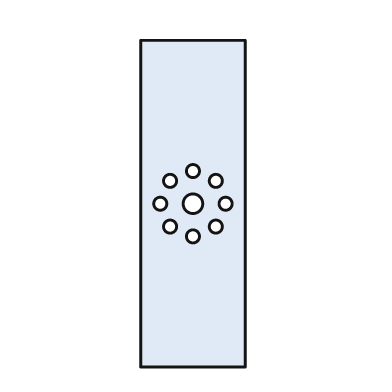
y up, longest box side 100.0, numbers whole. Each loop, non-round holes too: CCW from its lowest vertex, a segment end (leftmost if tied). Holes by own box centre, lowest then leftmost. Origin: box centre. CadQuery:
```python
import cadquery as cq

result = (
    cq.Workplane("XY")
    .moveTo(-16.0, -50.0)
    .lineTo(16.0, -50.0)
    .lineTo(16.0, 50.0)
    .lineTo(-16.0, 50.0)
    .close()
    .moveTo(0.0, -10.0)
    .circle(2.0)
    .moveTo(-7.0, -7.0)
    .circle(2.0)
    .moveTo(7.0, -7.0)
    .circle(2.0)
    .moveTo(-10.0, 0.0)
    .circle(2.0)
    .moveTo(0.0, 0.0)
    .circle(3.0)
    .moveTo(10.0, 0.0)
    .circle(2.0)
    .moveTo(-7.0, 7.0)
    .circle(2.0)
    .moveTo(7.0, 7.0)
    .circle(2.0)
    .moveTo(0.0, 10.0)
    .circle(2.0)
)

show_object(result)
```